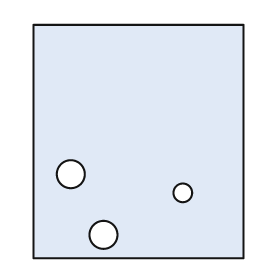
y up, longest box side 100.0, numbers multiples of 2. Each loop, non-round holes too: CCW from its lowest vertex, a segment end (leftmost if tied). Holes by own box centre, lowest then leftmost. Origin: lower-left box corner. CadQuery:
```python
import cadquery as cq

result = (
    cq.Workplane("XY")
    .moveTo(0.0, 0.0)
    .lineTo(90.0, 0.0)
    .lineTo(90.0, 100.0)
    .lineTo(0.0, 100.0)
    .close()
    .moveTo(30.0, 10.0)
    .circle(6.0)
    .moveTo(64.0, 28.0)
    .circle(4.0)
    .moveTo(16.0, 36.0)
    .circle(6.0)
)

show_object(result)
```